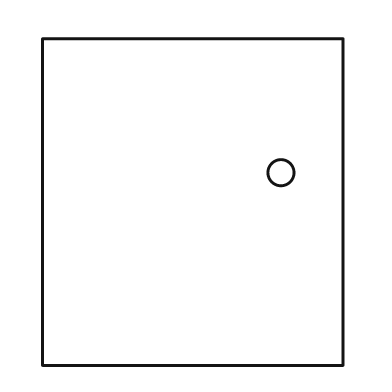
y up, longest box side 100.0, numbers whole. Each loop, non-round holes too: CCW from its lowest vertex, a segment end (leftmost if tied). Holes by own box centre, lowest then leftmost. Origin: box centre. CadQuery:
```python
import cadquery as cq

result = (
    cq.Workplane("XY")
    .moveTo(-46.0, -50.0)
    .lineTo(46.0, -50.0)
    .lineTo(46.0, 50.0)
    .lineTo(-46.0, 50.0)
    .close()
    .moveTo(27.0, 9.0)
    .circle(4.0)
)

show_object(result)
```